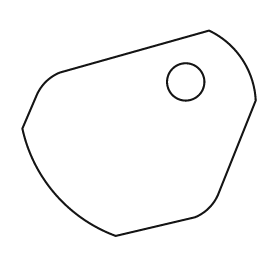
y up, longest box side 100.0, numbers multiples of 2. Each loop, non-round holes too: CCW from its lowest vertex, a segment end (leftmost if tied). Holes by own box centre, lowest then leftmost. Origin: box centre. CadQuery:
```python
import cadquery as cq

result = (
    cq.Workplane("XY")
    .moveTo(-10.0, -44.0)
    .lineTo(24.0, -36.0)
    .threePointArc((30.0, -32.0), (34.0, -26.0))
    .lineTo(50.0, 14.0)
    .threePointArc((44.0, 32.0), (30.0, 44.0))
    .lineTo(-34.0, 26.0)
    .threePointArc((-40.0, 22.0), (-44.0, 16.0))
    .lineTo(-50.0, 2.0)
    .threePointArc((-36.0, -26.0), (-10.0, -44.0))
    .close()
    .moveTo(20.0, 22.0)
    .circle(8.0)
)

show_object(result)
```